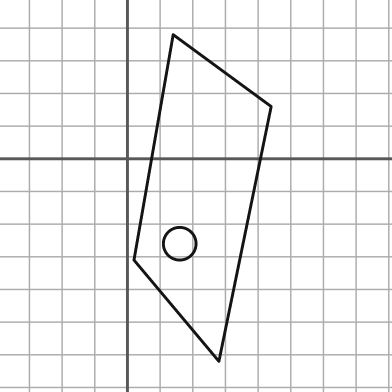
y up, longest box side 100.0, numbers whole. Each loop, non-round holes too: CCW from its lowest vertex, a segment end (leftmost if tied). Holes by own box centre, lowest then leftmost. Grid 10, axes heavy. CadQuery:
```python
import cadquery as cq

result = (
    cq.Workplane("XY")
    .moveTo(28.0, -62.0)
    .lineTo(44.0, 16.0)
    .lineTo(14.0, 38.0)
    .lineTo(2.0, -31.0)
    .close()
    .moveTo(16.0, -26.0)
    .circle(5.0)
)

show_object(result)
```